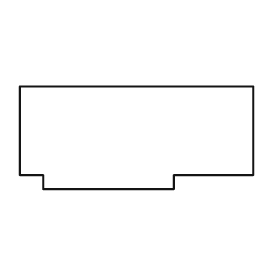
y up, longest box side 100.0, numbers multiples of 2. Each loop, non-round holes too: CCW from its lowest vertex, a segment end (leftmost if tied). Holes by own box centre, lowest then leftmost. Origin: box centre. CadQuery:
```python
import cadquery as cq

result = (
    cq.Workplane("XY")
    .moveTo(-40.0, -22.0)
    .lineTo(16.0, -22.0)
    .lineTo(16.0, -16.0)
    .lineTo(50.0, -16.0)
    .lineTo(50.0, 22.0)
    .lineTo(-50.0, 22.0)
    .lineTo(-50.0, -16.0)
    .lineTo(-40.0, -16.0)
    .close()
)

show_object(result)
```